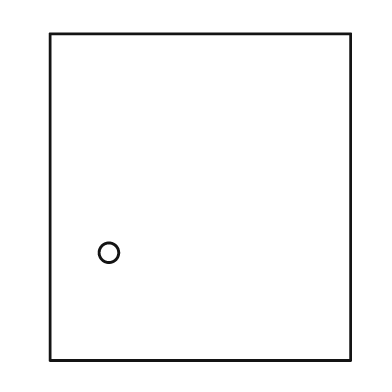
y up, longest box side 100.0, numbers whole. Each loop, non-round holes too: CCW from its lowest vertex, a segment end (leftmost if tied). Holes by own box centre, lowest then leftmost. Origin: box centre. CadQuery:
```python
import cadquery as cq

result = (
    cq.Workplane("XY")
    .moveTo(-46.0, -50.0)
    .lineTo(46.0, -50.0)
    .lineTo(46.0, 50.0)
    .lineTo(-46.0, 50.0)
    .close()
    .moveTo(-28.0, -17.0)
    .circle(3.0)
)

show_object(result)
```